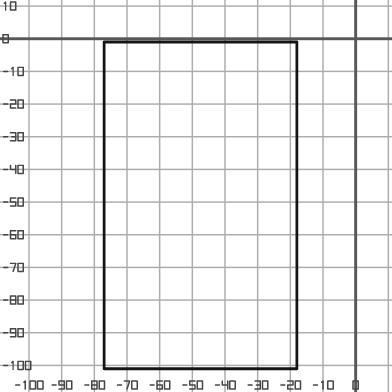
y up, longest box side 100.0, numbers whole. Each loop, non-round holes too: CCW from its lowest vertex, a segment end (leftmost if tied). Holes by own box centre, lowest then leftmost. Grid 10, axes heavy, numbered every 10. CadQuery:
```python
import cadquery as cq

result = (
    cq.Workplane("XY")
    .moveTo(-77.0, -101.0)
    .lineTo(-18.0, -101.0)
    .lineTo(-18.0, -1.0)
    .lineTo(-77.0, -1.0)
    .close()
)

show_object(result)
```